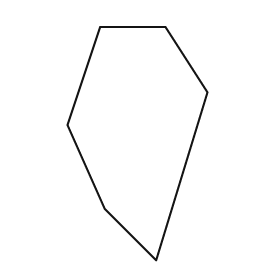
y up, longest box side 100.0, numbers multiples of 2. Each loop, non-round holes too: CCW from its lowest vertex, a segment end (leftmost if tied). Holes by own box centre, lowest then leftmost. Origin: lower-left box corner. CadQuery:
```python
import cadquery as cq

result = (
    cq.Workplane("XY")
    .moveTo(38.0, 0.0)
    .lineTo(60.0, 72.0)
    .lineTo(42.0, 100.0)
    .lineTo(14.0, 100.0)
    .lineTo(0.0, 58.0)
    .lineTo(16.0, 22.0)
    .close()
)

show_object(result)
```